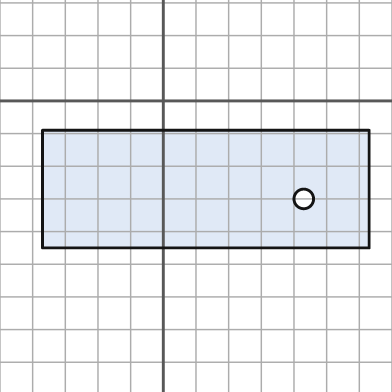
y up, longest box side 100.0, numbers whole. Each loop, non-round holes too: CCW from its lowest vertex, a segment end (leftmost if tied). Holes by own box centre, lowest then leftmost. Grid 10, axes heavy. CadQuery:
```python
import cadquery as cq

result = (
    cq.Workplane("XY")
    .moveTo(-37.0, -45.0)
    .lineTo(63.0, -45.0)
    .lineTo(63.0, -9.0)
    .lineTo(-37.0, -9.0)
    .close()
    .moveTo(43.0, -30.0)
    .circle(3.0)
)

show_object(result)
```